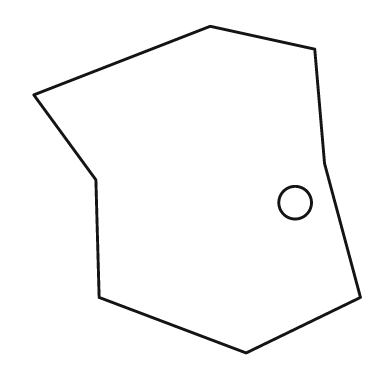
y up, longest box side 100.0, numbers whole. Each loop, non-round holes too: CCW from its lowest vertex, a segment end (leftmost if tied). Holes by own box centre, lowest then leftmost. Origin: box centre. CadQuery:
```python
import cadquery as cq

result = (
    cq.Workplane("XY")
    .moveTo(15.0, -50.0)
    .lineTo(50.0, -33.0)
    .lineTo(39.0, 8.0)
    .lineTo(36.0, 43.0)
    .lineTo(4.0, 50.0)
    .lineTo(-50.0, 29.0)
    .lineTo(-31.0, 3.0)
    .lineTo(-30.0, -33.0)
    .close()
    .moveTo(30.0, -4.0)
    .circle(5.0)
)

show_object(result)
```